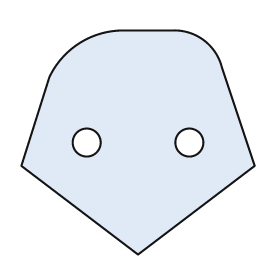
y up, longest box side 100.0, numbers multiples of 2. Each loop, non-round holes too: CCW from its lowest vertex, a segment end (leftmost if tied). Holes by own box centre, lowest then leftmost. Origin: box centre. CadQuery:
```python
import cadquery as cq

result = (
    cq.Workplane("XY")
    .moveTo(0.0, -48.0)
    .lineTo(50.0, -10.0)
    .lineTo(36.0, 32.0)
    .threePointArc((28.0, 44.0), (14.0, 48.0))
    .lineTo(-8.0, 48.0)
    .threePointArc((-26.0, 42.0), (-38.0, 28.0))
    .lineTo(-50.0, -10.0)
    .close()
    .moveTo(-22.0, 0.0)
    .circle(6.0)
    .moveTo(22.0, 0.0)
    .circle(6.0)
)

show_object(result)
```